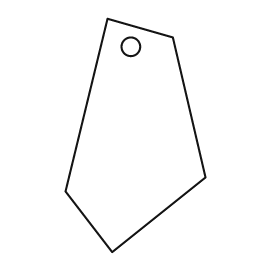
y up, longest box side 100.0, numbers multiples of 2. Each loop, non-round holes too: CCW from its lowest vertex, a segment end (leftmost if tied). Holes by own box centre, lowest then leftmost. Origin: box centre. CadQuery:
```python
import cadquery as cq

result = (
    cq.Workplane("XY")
    .moveTo(-10.0, -50.0)
    .lineTo(30.0, -18.0)
    .lineTo(16.0, 42.0)
    .lineTo(-12.0, 50.0)
    .lineTo(-30.0, -24.0)
    .close()
    .moveTo(-2.0, 38.0)
    .circle(4.0)
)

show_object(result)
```